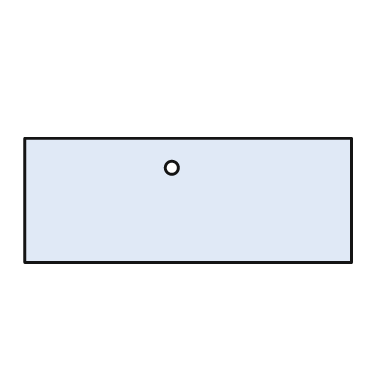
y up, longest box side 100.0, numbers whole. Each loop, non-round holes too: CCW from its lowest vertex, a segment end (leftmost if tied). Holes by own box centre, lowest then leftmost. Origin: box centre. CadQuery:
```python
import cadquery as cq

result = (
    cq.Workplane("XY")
    .moveTo(-50.0, -19.0)
    .lineTo(50.0, -19.0)
    .lineTo(50.0, 19.0)
    .lineTo(-50.0, 19.0)
    .close()
    .moveTo(-5.0, 10.0)
    .circle(2.0)
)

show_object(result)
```